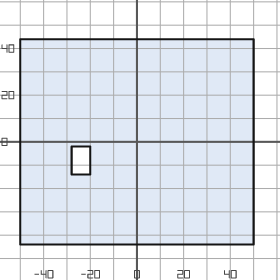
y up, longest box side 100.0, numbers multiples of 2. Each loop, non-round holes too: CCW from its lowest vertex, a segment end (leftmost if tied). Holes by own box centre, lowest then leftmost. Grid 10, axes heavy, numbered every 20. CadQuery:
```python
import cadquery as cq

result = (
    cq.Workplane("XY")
    .moveTo(-50.0, -44.0)
    .lineTo(50.0, -44.0)
    .lineTo(50.0, 44.0)
    .lineTo(-50.0, 44.0)
    .close()
    .moveTo(-28.0, -14.0)
    .lineTo(-20.0, -14.0)
    .lineTo(-20.0, -2.0)
    .lineTo(-28.0, -2.0)
    .close()
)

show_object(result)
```